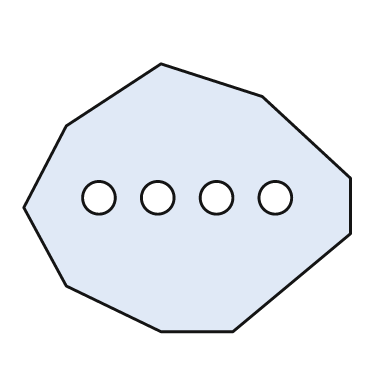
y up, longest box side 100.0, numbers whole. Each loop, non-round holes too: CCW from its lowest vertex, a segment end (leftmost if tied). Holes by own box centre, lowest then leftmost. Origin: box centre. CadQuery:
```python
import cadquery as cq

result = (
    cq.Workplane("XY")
    .moveTo(-8.0, -41.0)
    .lineTo(14.0, -41.0)
    .lineTo(50.0, -11.0)
    .lineTo(50.0, 6.0)
    .lineTo(23.0, 31.0)
    .lineTo(-8.0, 41.0)
    .lineTo(-37.0, 22.0)
    .lineTo(-50.0, -3.0)
    .lineTo(-37.0, -27.0)
    .close()
    .moveTo(-27.0, 0.0)
    .circle(5.0)
    .moveTo(-9.0, 0.0)
    .circle(5.0)
    .moveTo(9.0, 0.0)
    .circle(5.0)
    .moveTo(27.0, 0.0)
    .circle(5.0)
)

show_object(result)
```